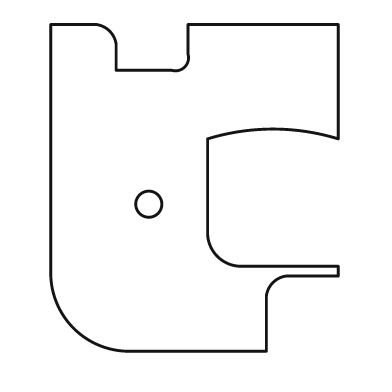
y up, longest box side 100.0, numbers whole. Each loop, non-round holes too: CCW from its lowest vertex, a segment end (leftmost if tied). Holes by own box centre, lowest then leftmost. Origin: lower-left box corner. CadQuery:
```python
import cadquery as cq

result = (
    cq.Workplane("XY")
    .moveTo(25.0, 0.0)
    .lineTo(66.0, 0.0)
    .lineTo(66.0, 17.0)
    .threePointArc((68.0, 21.0), (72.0, 23.0))
    .lineTo(88.0, 23.0)
    .lineTo(88.0, 26.0)
    .lineTo(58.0, 26.0)
    .threePointArc((51.0, 29.0), (48.0, 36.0))
    .lineTo(48.0, 65.0)
    .threePointArc((68.0, 68.0), (88.0, 65.0))
    .lineTo(88.0, 100.0)
    .lineTo(42.0, 100.0)
    .lineTo(42.0, 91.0)
    .threePointArc((41.0, 87.0), (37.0, 86.0))
    .lineTo(20.0, 86.0)
    .lineTo(20.0, 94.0)
    .threePointArc((18.0, 98.0), (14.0, 100.0))
    .lineTo(0.0, 100.0)
    .lineTo(0.0, 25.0)
    .threePointArc((7.0, 7.0), (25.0, 0.0))
    .close()
    .moveTo(30.0, 45.0)
    .circle(4.0)
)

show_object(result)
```